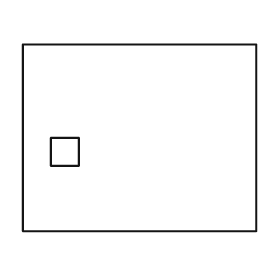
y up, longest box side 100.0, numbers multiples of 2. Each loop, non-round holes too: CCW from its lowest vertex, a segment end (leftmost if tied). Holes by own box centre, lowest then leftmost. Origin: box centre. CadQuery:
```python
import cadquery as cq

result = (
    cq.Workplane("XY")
    .moveTo(-50.0, -40.0)
    .lineTo(50.0, -40.0)
    .lineTo(50.0, 40.0)
    .lineTo(-50.0, 40.0)
    .close()
    .moveTo(-38.0, -12.0)
    .lineTo(-26.0, -12.0)
    .lineTo(-26.0, 0.0)
    .lineTo(-38.0, 0.0)
    .close()
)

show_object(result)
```